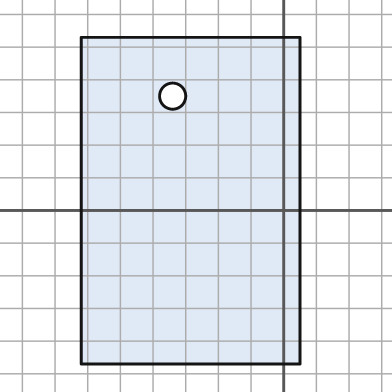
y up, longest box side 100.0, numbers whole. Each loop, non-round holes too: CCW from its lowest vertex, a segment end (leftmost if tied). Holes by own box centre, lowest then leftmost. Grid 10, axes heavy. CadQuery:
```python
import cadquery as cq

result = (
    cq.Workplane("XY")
    .moveTo(-62.0, -47.0)
    .lineTo(5.0, -47.0)
    .lineTo(5.0, 53.0)
    .lineTo(-62.0, 53.0)
    .close()
    .moveTo(-34.0, 35.0)
    .circle(4.0)
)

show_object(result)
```